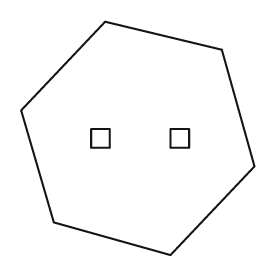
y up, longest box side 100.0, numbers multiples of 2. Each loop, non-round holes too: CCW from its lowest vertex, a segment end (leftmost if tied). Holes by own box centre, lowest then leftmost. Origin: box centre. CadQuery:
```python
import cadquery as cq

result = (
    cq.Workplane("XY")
    .moveTo(14.0, -50.0)
    .lineTo(50.0, -12.0)
    .lineTo(36.0, 38.0)
    .lineTo(-14.0, 50.0)
    .lineTo(-50.0, 12.0)
    .lineTo(-36.0, -36.0)
    .close()
    .moveTo(-20.0, -4.0)
    .lineTo(-12.0, -4.0)
    .lineTo(-12.0, 4.0)
    .lineTo(-20.0, 4.0)
    .close()
    .moveTo(14.0, -4.0)
    .lineTo(22.0, -4.0)
    .lineTo(22.0, 4.0)
    .lineTo(14.0, 4.0)
    .close()
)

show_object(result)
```